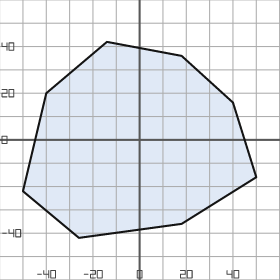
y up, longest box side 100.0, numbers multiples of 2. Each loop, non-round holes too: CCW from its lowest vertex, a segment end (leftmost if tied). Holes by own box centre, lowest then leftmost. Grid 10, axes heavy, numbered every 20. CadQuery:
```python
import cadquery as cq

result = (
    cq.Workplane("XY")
    .moveTo(-26.0, -42.0)
    .lineTo(18.0, -36.0)
    .lineTo(50.0, -16.0)
    .lineTo(40.0, 16.0)
    .lineTo(18.0, 36.0)
    .lineTo(-14.0, 42.0)
    .lineTo(-40.0, 20.0)
    .lineTo(-50.0, -22.0)
    .close()
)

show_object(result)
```